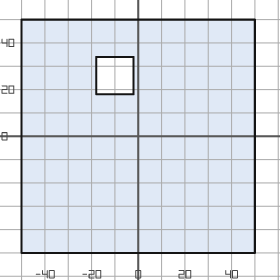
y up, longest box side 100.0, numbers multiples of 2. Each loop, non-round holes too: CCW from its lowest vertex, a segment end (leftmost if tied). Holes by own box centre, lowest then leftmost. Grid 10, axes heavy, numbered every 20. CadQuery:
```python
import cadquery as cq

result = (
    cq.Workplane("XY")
    .moveTo(-50.0, -50.0)
    .lineTo(50.0, -50.0)
    .lineTo(50.0, 50.0)
    .lineTo(-50.0, 50.0)
    .close()
    .moveTo(-18.0, 18.0)
    .lineTo(-2.0, 18.0)
    .lineTo(-2.0, 34.0)
    .lineTo(-18.0, 34.0)
    .close()
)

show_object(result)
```